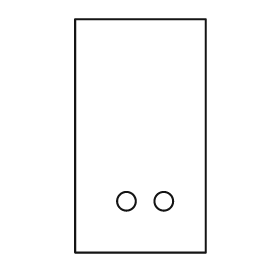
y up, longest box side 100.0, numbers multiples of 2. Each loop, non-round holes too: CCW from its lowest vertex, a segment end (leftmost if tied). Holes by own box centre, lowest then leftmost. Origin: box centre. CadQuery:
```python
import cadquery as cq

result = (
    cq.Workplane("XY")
    .moveTo(-28.0, -50.0)
    .lineTo(28.0, -50.0)
    .lineTo(28.0, 50.0)
    .lineTo(-28.0, 50.0)
    .close()
    .moveTo(-6.0, -28.0)
    .circle(4.0)
    .moveTo(10.0, -28.0)
    .circle(4.0)
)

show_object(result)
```